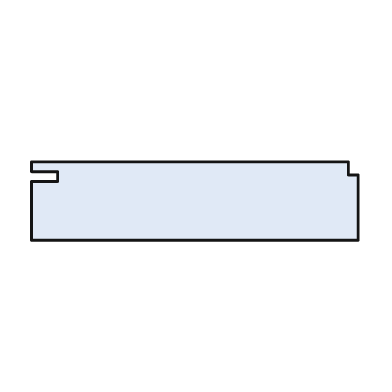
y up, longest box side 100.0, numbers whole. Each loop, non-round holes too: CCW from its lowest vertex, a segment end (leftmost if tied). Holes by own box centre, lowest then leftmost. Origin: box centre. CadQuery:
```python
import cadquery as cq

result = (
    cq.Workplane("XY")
    .moveTo(-50.0, -12.0)
    .lineTo(50.0, -12.0)
    .lineTo(50.0, 8.0)
    .lineTo(47.0, 8.0)
    .lineTo(47.0, 12.0)
    .lineTo(-50.0, 12.0)
    .lineTo(-50.0, 9.0)
    .lineTo(-42.0, 9.0)
    .lineTo(-42.0, 6.0)
    .lineTo(-50.0, 6.0)
    .close()
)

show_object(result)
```